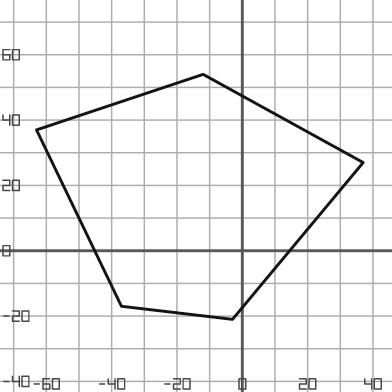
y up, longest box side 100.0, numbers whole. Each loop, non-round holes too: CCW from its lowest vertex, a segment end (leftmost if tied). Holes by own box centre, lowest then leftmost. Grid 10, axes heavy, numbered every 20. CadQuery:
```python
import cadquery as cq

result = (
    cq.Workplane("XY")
    .moveTo(-3.0, -21.0)
    .lineTo(37.0, 27.0)
    .lineTo(-12.0, 54.0)
    .lineTo(-63.0, 37.0)
    .lineTo(-37.0, -17.0)
    .close()
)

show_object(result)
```